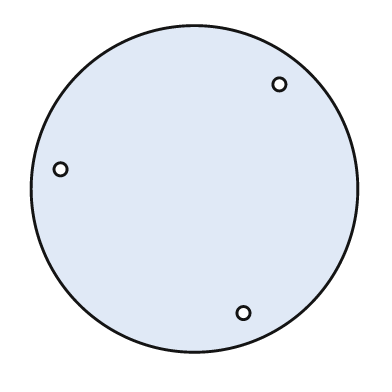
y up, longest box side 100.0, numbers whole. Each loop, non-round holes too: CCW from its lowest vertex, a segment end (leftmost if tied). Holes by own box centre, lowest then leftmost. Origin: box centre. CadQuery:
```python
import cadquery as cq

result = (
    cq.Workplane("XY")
    .moveTo(0.0, 0.0)
    .circle(50.0)
    .moveTo(15.0, -38.0)
    .circle(2.0)
    .moveTo(-41.0, 6.0)
    .circle(2.0)
    .moveTo(26.0, 32.0)
    .circle(2.0)
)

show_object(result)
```